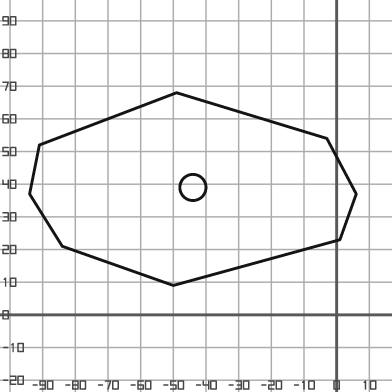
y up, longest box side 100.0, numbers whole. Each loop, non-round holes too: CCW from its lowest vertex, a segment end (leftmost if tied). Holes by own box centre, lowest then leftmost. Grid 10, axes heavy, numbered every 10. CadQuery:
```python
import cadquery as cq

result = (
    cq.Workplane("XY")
    .moveTo(-50.0, 9.0)
    .lineTo(1.0, 23.0)
    .lineTo(6.0, 37.0)
    .lineTo(-3.0, 54.0)
    .lineTo(-49.0, 68.0)
    .lineTo(-91.0, 52.0)
    .lineTo(-94.0, 37.0)
    .lineTo(-84.0, 21.0)
    .close()
    .moveTo(-44.0, 39.0)
    .circle(4.0)
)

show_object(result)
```